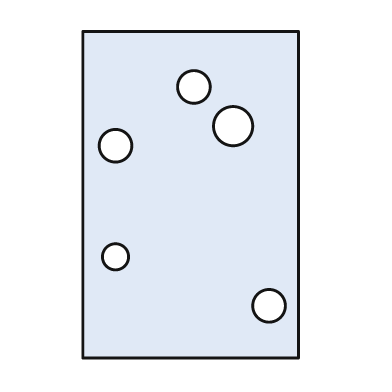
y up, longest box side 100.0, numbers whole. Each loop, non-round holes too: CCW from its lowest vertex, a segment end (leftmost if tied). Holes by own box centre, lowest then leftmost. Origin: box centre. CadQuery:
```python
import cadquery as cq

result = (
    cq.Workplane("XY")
    .moveTo(-33.0, -50.0)
    .lineTo(33.0, -50.0)
    .lineTo(33.0, 50.0)
    .lineTo(-33.0, 50.0)
    .close()
    .moveTo(24.0, -34.0)
    .circle(5.0)
    .moveTo(-23.0, -19.0)
    .circle(4.0)
    .moveTo(-23.0, 15.0)
    .circle(5.0)
    .moveTo(13.0, 21.0)
    .circle(6.0)
    .moveTo(1.0, 33.0)
    .circle(5.0)
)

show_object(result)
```